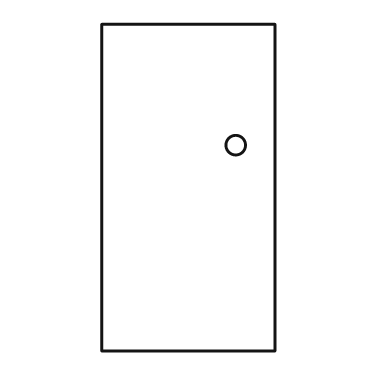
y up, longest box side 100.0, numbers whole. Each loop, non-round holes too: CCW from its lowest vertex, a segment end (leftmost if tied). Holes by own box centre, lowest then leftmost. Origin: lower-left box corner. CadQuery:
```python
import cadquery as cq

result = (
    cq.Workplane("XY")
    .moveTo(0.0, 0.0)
    .lineTo(53.0, 0.0)
    .lineTo(53.0, 100.0)
    .lineTo(0.0, 100.0)
    .close()
    .moveTo(41.0, 63.0)
    .circle(3.0)
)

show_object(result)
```